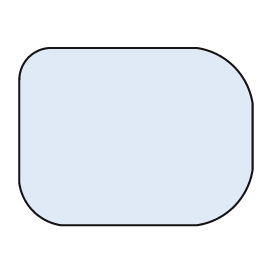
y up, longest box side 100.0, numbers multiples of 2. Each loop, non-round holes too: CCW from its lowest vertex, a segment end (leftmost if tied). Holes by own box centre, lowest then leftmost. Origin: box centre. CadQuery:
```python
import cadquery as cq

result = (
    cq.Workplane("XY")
    .moveTo(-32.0, -38.0)
    .lineTo(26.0, -38.0)
    .threePointArc((42.0, -30.0), (50.0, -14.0))
    .lineTo(50.0, 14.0)
    .threePointArc((42.0, 30.0), (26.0, 38.0))
    .lineTo(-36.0, 38.0)
    .threePointArc((-46.0, 34.0), (-50.0, 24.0))
    .lineTo(-50.0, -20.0)
    .threePointArc((-44.0, -32.0), (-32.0, -38.0))
    .close()
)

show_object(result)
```